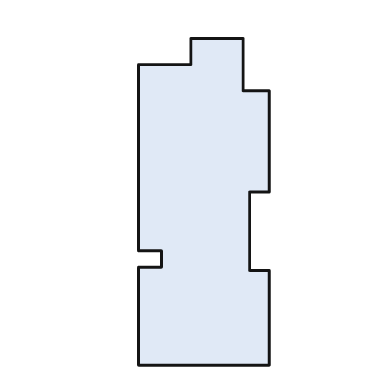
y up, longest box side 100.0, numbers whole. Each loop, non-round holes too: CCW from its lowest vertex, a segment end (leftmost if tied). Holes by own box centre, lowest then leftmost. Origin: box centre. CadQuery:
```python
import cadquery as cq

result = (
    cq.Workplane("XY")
    .moveTo(-20.0, -50.0)
    .lineTo(20.0, -50.0)
    .lineTo(20.0, -21.0)
    .lineTo(14.0, -21.0)
    .lineTo(14.0, 3.0)
    .lineTo(20.0, 3.0)
    .lineTo(20.0, 34.0)
    .lineTo(12.0, 34.0)
    .lineTo(12.0, 50.0)
    .lineTo(-4.0, 50.0)
    .lineTo(-4.0, 42.0)
    .lineTo(-20.0, 42.0)
    .lineTo(-20.0, -15.0)
    .lineTo(-13.0, -15.0)
    .lineTo(-13.0, -20.0)
    .lineTo(-20.0, -20.0)
    .close()
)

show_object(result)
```